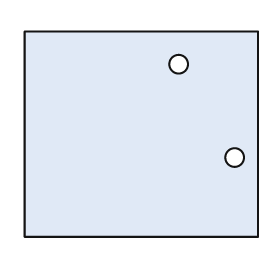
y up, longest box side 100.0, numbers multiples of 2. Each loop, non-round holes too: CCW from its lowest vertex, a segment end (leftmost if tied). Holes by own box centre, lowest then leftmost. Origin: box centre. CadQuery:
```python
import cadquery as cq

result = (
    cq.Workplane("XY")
    .moveTo(-50.0, -44.0)
    .lineTo(50.0, -44.0)
    .lineTo(50.0, 44.0)
    .lineTo(-50.0, 44.0)
    .close()
    .moveTo(40.0, -10.0)
    .circle(4.0)
    .moveTo(16.0, 30.0)
    .circle(4.0)
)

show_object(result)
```